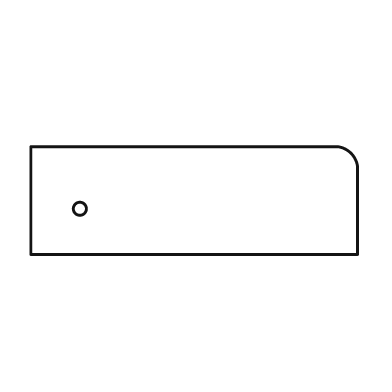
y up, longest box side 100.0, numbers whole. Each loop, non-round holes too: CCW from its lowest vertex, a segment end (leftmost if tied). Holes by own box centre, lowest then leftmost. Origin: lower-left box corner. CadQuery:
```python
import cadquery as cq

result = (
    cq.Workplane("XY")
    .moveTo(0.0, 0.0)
    .lineTo(100.0, 0.0)
    .lineTo(100.0, 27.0)
    .threePointArc((98.0, 31.0), (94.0, 33.0))
    .lineTo(0.0, 33.0)
    .close()
    .moveTo(15.0, 14.0)
    .circle(2.0)
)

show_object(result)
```